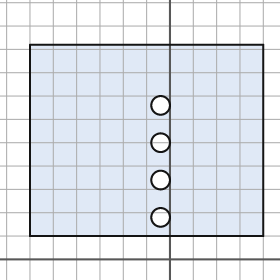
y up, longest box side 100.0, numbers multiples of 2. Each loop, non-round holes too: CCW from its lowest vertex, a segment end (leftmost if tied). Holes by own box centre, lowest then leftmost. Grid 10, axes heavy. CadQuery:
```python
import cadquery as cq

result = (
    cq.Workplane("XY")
    .moveTo(-60.0, 10.0)
    .lineTo(40.0, 10.0)
    .lineTo(40.0, 92.0)
    .lineTo(-60.0, 92.0)
    .close()
    .moveTo(-4.0, 18.0)
    .circle(4.0)
    .moveTo(-4.0, 34.0)
    .circle(4.0)
    .moveTo(-4.0, 50.0)
    .circle(4.0)
    .moveTo(-4.0, 66.0)
    .circle(4.0)
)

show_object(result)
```